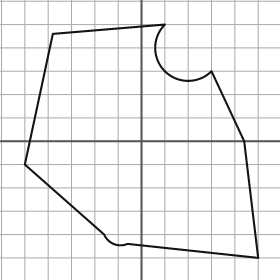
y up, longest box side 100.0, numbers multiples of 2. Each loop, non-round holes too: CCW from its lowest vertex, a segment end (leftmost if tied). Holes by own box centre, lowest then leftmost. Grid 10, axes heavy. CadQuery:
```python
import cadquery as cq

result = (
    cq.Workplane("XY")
    .moveTo(50.0, -50.0)
    .lineTo(44.0, 0.0)
    .lineTo(30.0, 30.0)
    .threePointArc((10.0, 30.0), (10.0, 50.0))
    .lineTo(-38.0, 46.0)
    .lineTo(-50.0, -10.0)
    .lineTo(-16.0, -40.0)
    .threePointArc((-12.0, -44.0), (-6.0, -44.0))
    .close()
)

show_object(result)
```